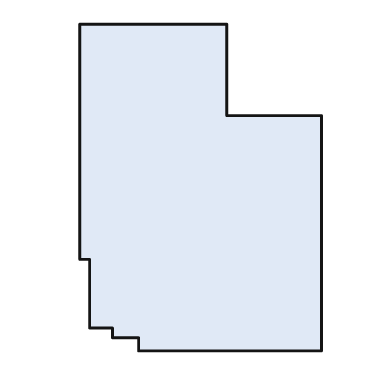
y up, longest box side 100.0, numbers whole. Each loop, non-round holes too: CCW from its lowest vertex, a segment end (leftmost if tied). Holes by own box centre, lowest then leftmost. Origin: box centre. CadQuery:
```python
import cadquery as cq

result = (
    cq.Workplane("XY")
    .moveTo(-19.0, -50.0)
    .lineTo(37.0, -50.0)
    .lineTo(37.0, 22.0)
    .lineTo(8.0, 22.0)
    .lineTo(8.0, 50.0)
    .lineTo(-37.0, 50.0)
    .lineTo(-37.0, -22.0)
    .lineTo(-34.0, -22.0)
    .lineTo(-34.0, -43.0)
    .lineTo(-27.0, -43.0)
    .lineTo(-27.0, -46.0)
    .lineTo(-19.0, -46.0)
    .close()
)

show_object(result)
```